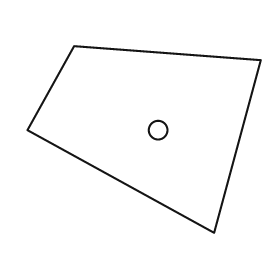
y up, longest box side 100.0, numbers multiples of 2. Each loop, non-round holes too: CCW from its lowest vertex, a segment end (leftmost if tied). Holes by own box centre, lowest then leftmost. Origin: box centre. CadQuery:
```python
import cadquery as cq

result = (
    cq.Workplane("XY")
    .moveTo(30.0, -40.0)
    .lineTo(50.0, 34.0)
    .lineTo(-30.0, 40.0)
    .lineTo(-50.0, 4.0)
    .close()
    .moveTo(6.0, 4.0)
    .circle(4.0)
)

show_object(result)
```